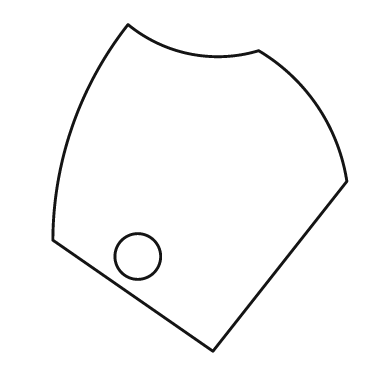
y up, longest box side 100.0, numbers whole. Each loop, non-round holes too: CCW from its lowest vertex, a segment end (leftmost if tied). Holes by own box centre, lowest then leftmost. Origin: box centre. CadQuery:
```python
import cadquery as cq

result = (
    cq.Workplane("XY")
    .moveTo(4.0, -50.0)
    .lineTo(45.0, 2.0)
    .threePointArc((36.0, 25.0), (18.0, 42.0))
    .threePointArc((-3.0, 41.0), (-22.0, 50.0))
    .threePointArc((-39.0, 19.0), (-45.0, -16.0))
    .close()
    .moveTo(-19.0, -21.0)
    .circle(7.0)
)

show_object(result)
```